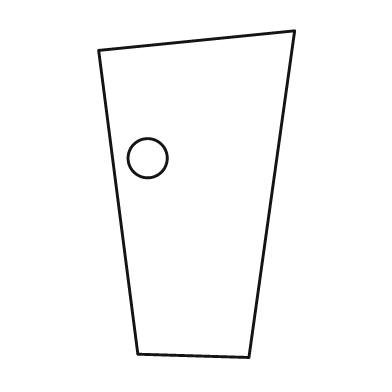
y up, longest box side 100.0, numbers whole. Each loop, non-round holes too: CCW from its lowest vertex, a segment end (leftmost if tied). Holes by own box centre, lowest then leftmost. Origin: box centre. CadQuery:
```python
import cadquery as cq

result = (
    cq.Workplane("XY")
    .moveTo(16.0, -50.0)
    .lineTo(30.0, 50.0)
    .lineTo(-30.0, 44.0)
    .lineTo(-18.0, -49.0)
    .close()
    .moveTo(-15.0, 11.0)
    .circle(6.0)
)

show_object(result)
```